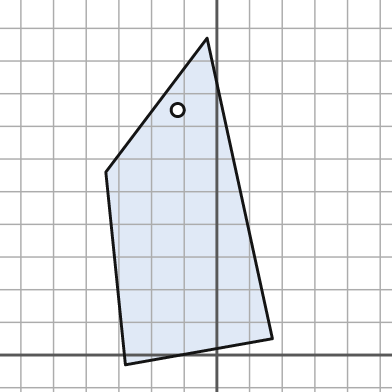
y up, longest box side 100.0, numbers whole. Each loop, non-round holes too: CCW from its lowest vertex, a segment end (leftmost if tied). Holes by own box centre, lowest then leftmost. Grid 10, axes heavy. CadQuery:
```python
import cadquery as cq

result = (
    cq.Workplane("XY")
    .moveTo(-28.0, -3.0)
    .lineTo(17.0, 5.0)
    .lineTo(-3.0, 97.0)
    .lineTo(-34.0, 56.0)
    .close()
    .moveTo(-12.0, 75.0)
    .circle(2.0)
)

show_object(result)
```